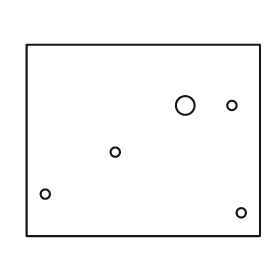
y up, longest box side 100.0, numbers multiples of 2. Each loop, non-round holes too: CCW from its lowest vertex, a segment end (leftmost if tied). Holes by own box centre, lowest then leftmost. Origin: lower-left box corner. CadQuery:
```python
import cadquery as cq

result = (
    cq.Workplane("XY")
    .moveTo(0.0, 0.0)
    .lineTo(100.0, 0.0)
    .lineTo(100.0, 82.0)
    .lineTo(0.0, 82.0)
    .close()
    .moveTo(92.0, 10.0)
    .circle(2.0)
    .moveTo(8.0, 18.0)
    .circle(2.0)
    .moveTo(38.0, 36.0)
    .circle(2.0)
    .moveTo(68.0, 56.0)
    .circle(4.0)
    .moveTo(88.0, 56.0)
    .circle(2.0)
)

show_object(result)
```